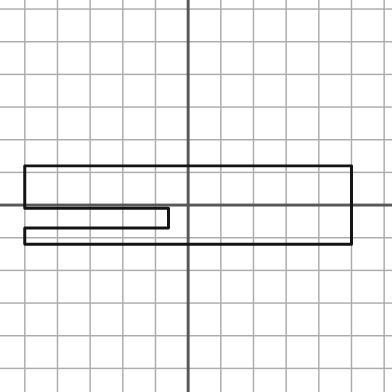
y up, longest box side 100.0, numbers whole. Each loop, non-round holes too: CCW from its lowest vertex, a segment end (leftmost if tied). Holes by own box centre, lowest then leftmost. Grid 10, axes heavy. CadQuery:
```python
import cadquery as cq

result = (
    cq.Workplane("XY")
    .moveTo(-50.0, -12.0)
    .lineTo(50.0, -12.0)
    .lineTo(50.0, 12.0)
    .lineTo(-50.0, 12.0)
    .lineTo(-50.0, -1.0)
    .lineTo(-6.0, -1.0)
    .lineTo(-6.0, -7.0)
    .lineTo(-50.0, -7.0)
    .close()
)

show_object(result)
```